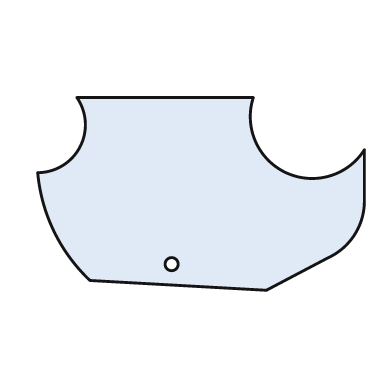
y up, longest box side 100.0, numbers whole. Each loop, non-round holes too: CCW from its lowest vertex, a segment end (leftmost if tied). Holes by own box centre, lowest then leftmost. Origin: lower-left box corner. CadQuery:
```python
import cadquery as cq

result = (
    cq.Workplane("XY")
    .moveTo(70.0, 0.0)
    .lineTo(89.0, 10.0)
    .threePointArc((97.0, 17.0), (100.0, 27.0))
    .lineTo(100.0, 43.0)
    .threePointArc((76.0, 36.0), (66.0, 59.0))
    .lineTo(12.0, 59.0)
    .threePointArc((13.0, 44.0), (0.0, 36.0))
    .threePointArc((5.0, 18.0), (16.0, 3.0))
    .close()
    .moveTo(41.0, 8.0)
    .circle(2.0)
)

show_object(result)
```